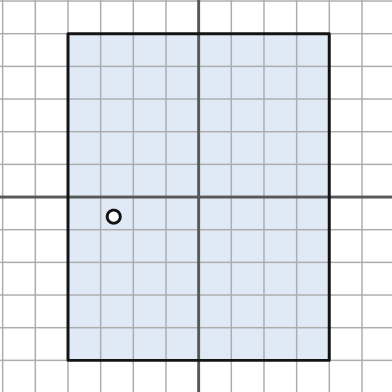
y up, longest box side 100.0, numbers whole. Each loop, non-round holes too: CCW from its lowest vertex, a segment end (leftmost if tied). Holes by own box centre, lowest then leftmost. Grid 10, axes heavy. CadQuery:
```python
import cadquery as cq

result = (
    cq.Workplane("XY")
    .moveTo(-40.0, -50.0)
    .lineTo(40.0, -50.0)
    .lineTo(40.0, 50.0)
    .lineTo(-40.0, 50.0)
    .close()
    .moveTo(-26.0, -6.0)
    .circle(2.0)
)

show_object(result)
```